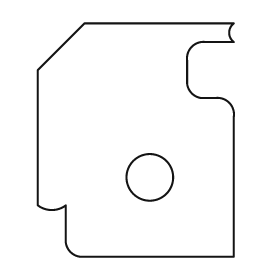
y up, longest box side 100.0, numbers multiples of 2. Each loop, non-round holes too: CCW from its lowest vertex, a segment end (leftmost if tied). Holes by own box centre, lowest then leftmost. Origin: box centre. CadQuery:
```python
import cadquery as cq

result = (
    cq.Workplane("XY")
    .moveTo(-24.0, -50.0)
    .lineTo(42.0, -50.0)
    .lineTo(42.0, 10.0)
    .threePointArc((40.0, 16.0), (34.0, 18.0))
    .lineTo(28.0, 18.0)
    .threePointArc((24.0, 20.0), (22.0, 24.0))
    .lineTo(22.0, 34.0)
    .threePointArc((24.0, 40.0), (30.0, 42.0))
    .lineTo(42.0, 42.0)
    .threePointArc((40.0, 46.0), (42.0, 50.0))
    .lineTo(-22.0, 50.0)
    .lineTo(-42.0, 30.0)
    .lineTo(-42.0, -28.0)
    .threePointArc((-36.0, -30.0), (-30.0, -28.0))
    .lineTo(-30.0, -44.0)
    .threePointArc((-28.0, -48.0), (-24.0, -50.0))
    .close()
    .moveTo(6.0, -16.0)
    .circle(10.0)
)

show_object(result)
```